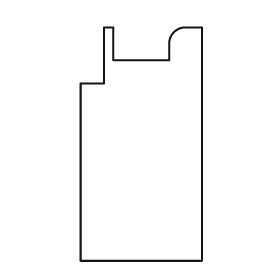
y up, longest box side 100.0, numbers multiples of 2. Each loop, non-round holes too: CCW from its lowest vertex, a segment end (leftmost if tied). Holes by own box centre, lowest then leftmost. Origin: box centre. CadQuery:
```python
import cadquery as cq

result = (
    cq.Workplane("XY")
    .moveTo(-26.0, -50.0)
    .lineTo(26.0, -50.0)
    .lineTo(26.0, 50.0)
    .lineTo(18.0, 50.0)
    .threePointArc((14.0, 48.0), (12.0, 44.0))
    .lineTo(12.0, 36.0)
    .lineTo(-12.0, 36.0)
    .lineTo(-12.0, 50.0)
    .lineTo(-16.0, 50.0)
    .lineTo(-16.0, 26.0)
    .lineTo(-26.0, 26.0)
    .close()
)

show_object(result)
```